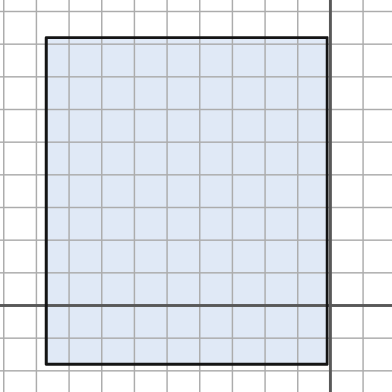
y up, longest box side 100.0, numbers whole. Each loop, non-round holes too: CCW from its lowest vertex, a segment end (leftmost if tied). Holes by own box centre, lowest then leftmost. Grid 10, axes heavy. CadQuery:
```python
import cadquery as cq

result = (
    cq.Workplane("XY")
    .moveTo(-87.0, -18.0)
    .lineTo(-1.0, -18.0)
    .lineTo(-1.0, 82.0)
    .lineTo(-87.0, 82.0)
    .close()
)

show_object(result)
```